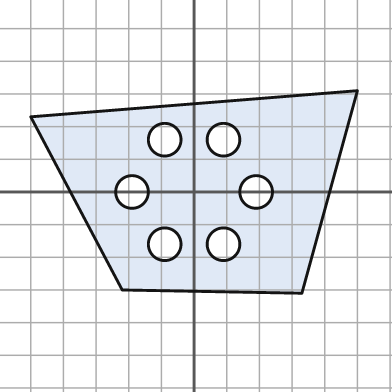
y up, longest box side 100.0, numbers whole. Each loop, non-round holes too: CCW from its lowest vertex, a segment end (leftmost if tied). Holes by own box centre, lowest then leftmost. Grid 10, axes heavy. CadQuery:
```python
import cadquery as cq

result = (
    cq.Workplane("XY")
    .moveTo(33.0, -31.0)
    .lineTo(50.0, 31.0)
    .lineTo(-50.0, 23.0)
    .lineTo(-22.0, -30.0)
    .close()
    .moveTo(-9.0, -16.0)
    .circle(5.0)
    .moveTo(9.0, -16.0)
    .circle(5.0)
    .moveTo(-19.0, 0.0)
    .circle(5.0)
    .moveTo(19.0, 0.0)
    .circle(5.0)
    .moveTo(-9.0, 16.0)
    .circle(5.0)
    .moveTo(9.0, 16.0)
    .circle(5.0)
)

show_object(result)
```